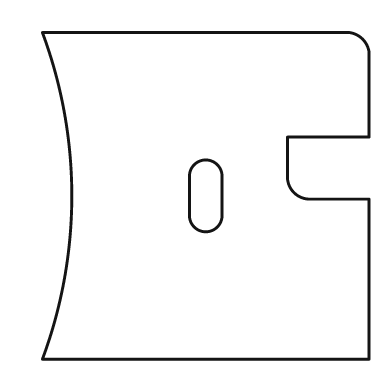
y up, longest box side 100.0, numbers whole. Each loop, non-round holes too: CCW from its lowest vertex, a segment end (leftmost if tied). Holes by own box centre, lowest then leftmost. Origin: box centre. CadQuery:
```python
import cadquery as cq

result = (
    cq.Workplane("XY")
    .moveTo(-50.0, -50.0)
    .lineTo(50.0, -50.0)
    .lineTo(50.0, -1.0)
    .lineTo(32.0, -1.0)
    .threePointArc((27.0, 1.0), (25.0, 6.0))
    .lineTo(25.0, 18.0)
    .lineTo(50.0, 18.0)
    .lineTo(50.0, 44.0)
    .threePointArc((48.0, 48.0), (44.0, 50.0))
    .lineTo(-50.0, 50.0)
    .threePointArc((-41.0, 0.0), (-50.0, -50.0))
    .close()
    .moveTo(-5.0, -6.0)
    .threePointArc((0.0, -11.0), (5.0, -6.0))
    .lineTo(5.0, 6.0)
    .threePointArc((0.0, 11.0), (-5.0, 6.0))
    .close()
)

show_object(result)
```